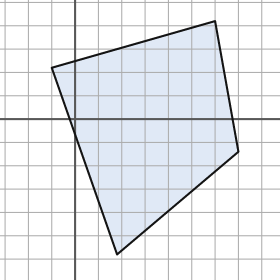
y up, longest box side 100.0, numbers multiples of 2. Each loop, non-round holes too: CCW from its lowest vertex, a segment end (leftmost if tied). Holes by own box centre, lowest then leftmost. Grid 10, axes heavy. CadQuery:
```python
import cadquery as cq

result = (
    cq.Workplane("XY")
    .moveTo(18.0, -58.0)
    .lineTo(70.0, -14.0)
    .lineTo(60.0, 42.0)
    .lineTo(-10.0, 22.0)
    .close()
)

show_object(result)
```